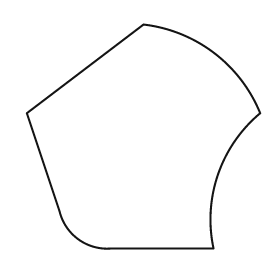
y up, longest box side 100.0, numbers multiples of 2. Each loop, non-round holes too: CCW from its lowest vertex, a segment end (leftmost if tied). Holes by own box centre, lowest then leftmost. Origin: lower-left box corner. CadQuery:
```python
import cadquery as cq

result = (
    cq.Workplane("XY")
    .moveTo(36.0, 0.0)
    .lineTo(80.0, 0.0)
    .threePointArc((82.0, 32.0), (100.0, 58.0))
    .threePointArc((80.0, 84.0), (50.0, 96.0))
    .lineTo(0.0, 58.0)
    .lineTo(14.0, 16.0)
    .threePointArc((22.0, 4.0), (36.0, 0.0))
    .close()
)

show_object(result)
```